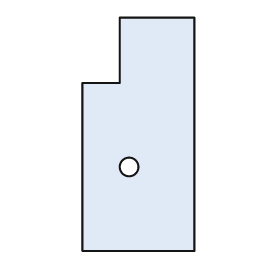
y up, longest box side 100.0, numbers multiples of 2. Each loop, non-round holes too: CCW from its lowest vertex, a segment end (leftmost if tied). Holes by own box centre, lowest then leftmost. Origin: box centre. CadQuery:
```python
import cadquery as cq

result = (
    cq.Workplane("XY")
    .moveTo(-24.0, -50.0)
    .lineTo(24.0, -50.0)
    .lineTo(24.0, 50.0)
    .lineTo(-8.0, 50.0)
    .lineTo(-8.0, 22.0)
    .lineTo(-24.0, 22.0)
    .close()
    .moveTo(-4.0, -14.0)
    .circle(4.0)
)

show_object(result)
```